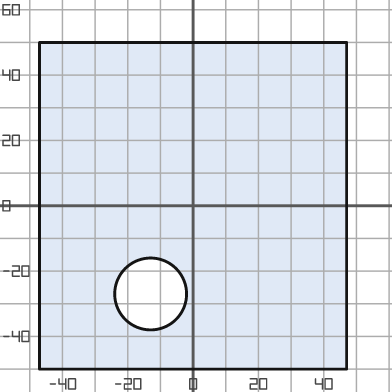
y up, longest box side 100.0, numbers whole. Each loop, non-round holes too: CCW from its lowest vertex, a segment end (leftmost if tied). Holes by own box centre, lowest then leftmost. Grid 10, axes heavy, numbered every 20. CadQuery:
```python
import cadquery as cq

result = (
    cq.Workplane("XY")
    .moveTo(-47.0, -50.0)
    .lineTo(47.0, -50.0)
    .lineTo(47.0, 50.0)
    .lineTo(-47.0, 50.0)
    .close()
    .moveTo(-13.0, -27.0)
    .circle(11.0)
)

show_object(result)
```